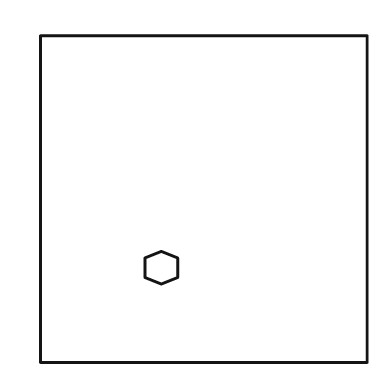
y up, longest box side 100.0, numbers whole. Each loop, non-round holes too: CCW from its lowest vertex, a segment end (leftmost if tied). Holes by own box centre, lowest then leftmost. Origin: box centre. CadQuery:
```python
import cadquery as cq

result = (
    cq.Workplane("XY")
    .moveTo(-50.0, -50.0)
    .lineTo(50.0, -50.0)
    .lineTo(50.0, 50.0)
    .lineTo(-50.0, 50.0)
    .close()
    .moveTo(-13.0, -26.0)
    .lineTo(-8.0, -24.0)
    .lineTo(-8.0, -18.0)
    .lineTo(-13.0, -16.0)
    .lineTo(-18.0, -18.0)
    .lineTo(-18.0, -24.0)
    .close()
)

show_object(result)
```